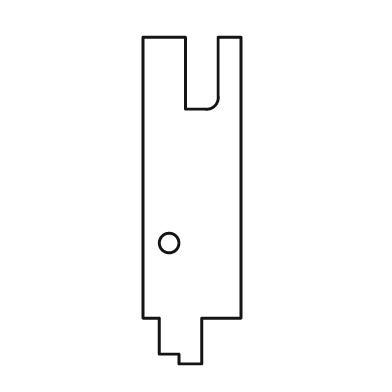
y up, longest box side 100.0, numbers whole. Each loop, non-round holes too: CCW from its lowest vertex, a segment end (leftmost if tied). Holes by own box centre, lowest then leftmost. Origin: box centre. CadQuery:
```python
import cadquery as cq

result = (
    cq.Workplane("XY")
    .moveTo(-4.0, -50.0)
    .lineTo(3.0, -50.0)
    .lineTo(3.0, -36.0)
    .lineTo(15.0, -36.0)
    .lineTo(15.0, 50.0)
    .lineTo(8.0, 50.0)
    .lineTo(8.0, 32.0)
    .threePointArc((7.0, 29.0), (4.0, 28.0))
    .lineTo(-2.0, 28.0)
    .lineTo(-2.0, 50.0)
    .lineTo(-15.0, 50.0)
    .lineTo(-15.0, -36.0)
    .lineTo(-10.0, -36.0)
    .lineTo(-10.0, -47.0)
    .lineTo(-4.0, -47.0)
    .close()
    .moveTo(-7.0, -13.0)
    .circle(3.0)
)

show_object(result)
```